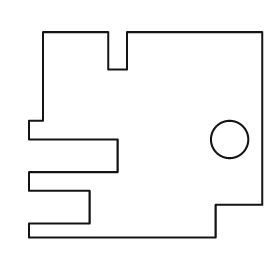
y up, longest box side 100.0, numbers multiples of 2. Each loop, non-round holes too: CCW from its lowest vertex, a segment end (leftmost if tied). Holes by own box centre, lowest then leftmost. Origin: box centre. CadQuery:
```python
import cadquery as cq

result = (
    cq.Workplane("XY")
    .moveTo(-50.0, -44.0)
    .lineTo(30.0, -44.0)
    .lineTo(30.0, -30.0)
    .lineTo(50.0, -30.0)
    .lineTo(50.0, 44.0)
    .lineTo(-8.0, 44.0)
    .lineTo(-8.0, 28.0)
    .lineTo(-16.0, 28.0)
    .lineTo(-16.0, 44.0)
    .lineTo(-44.0, 44.0)
    .lineTo(-44.0, 6.0)
    .lineTo(-50.0, 6.0)
    .lineTo(-50.0, -2.0)
    .lineTo(-12.0, -2.0)
    .lineTo(-12.0, -16.0)
    .lineTo(-50.0, -16.0)
    .lineTo(-50.0, -24.0)
    .lineTo(-24.0, -24.0)
    .lineTo(-24.0, -38.0)
    .lineTo(-50.0, -38.0)
    .close()
    .moveTo(36.0, -2.0)
    .circle(8.0)
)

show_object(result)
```